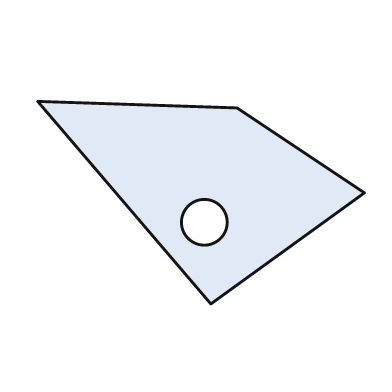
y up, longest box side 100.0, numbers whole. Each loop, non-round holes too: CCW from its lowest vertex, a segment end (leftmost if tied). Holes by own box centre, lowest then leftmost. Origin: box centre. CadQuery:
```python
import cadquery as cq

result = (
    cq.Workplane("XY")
    .moveTo(3.0, -31.0)
    .lineTo(50.0, 3.0)
    .lineTo(11.0, 29.0)
    .lineTo(-50.0, 31.0)
    .close()
    .moveTo(1.0, -6.0)
    .circle(7.0)
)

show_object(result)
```